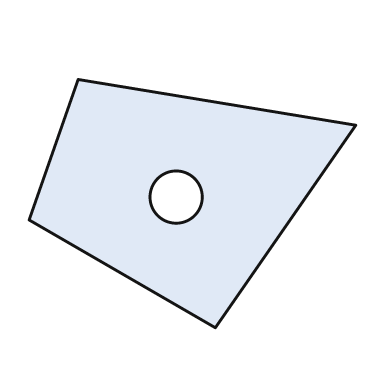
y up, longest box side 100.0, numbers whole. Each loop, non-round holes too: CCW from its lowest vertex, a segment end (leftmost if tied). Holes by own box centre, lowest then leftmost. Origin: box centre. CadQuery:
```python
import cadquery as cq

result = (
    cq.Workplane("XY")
    .moveTo(7.0, -38.0)
    .lineTo(50.0, 24.0)
    .lineTo(-35.0, 38.0)
    .lineTo(-50.0, -5.0)
    .close()
    .moveTo(-5.0, 2.0)
    .circle(8.0)
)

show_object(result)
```